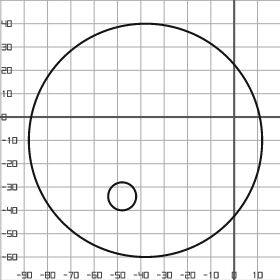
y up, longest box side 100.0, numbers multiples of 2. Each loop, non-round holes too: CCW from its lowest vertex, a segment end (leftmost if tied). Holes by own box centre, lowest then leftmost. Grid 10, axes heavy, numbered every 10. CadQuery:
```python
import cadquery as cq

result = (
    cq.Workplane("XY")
    .moveTo(-38.0, -10.0)
    .circle(50.0)
    .moveTo(-48.0, -34.0)
    .circle(6.0)
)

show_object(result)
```